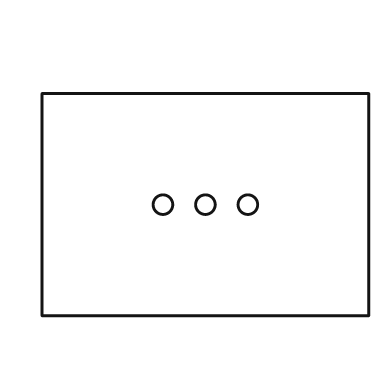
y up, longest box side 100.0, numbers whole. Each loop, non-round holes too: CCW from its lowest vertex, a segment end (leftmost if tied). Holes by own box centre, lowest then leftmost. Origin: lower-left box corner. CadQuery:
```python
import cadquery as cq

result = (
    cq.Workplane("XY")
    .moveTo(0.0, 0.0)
    .lineTo(100.0, 0.0)
    .lineTo(100.0, 68.0)
    .lineTo(0.0, 68.0)
    .close()
    .moveTo(37.0, 34.0)
    .circle(3.0)
    .moveTo(50.0, 34.0)
    .circle(3.0)
    .moveTo(63.0, 34.0)
    .circle(3.0)
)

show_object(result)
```